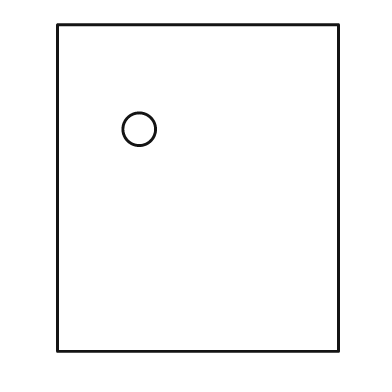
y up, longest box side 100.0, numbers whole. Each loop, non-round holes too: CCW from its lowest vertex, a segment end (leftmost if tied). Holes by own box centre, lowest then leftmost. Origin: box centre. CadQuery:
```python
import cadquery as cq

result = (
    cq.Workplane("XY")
    .moveTo(-43.0, -50.0)
    .lineTo(43.0, -50.0)
    .lineTo(43.0, 50.0)
    .lineTo(-43.0, 50.0)
    .close()
    .moveTo(-18.0, 18.0)
    .circle(5.0)
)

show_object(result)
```